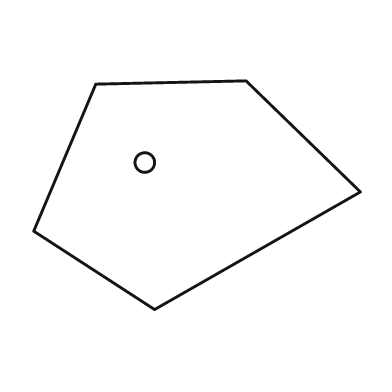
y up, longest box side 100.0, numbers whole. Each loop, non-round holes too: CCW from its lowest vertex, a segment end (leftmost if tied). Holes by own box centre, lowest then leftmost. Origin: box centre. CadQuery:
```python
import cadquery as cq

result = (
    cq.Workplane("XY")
    .moveTo(-13.0, -35.0)
    .lineTo(50.0, 1.0)
    .lineTo(15.0, 35.0)
    .lineTo(-31.0, 34.0)
    .lineTo(-50.0, -11.0)
    .close()
    .moveTo(-16.0, 10.0)
    .circle(3.0)
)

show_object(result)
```